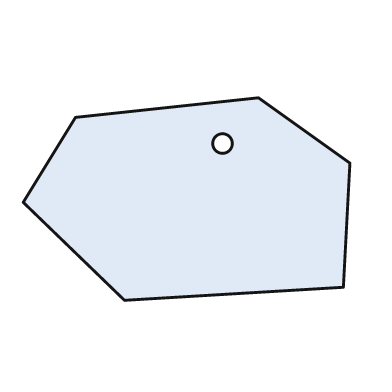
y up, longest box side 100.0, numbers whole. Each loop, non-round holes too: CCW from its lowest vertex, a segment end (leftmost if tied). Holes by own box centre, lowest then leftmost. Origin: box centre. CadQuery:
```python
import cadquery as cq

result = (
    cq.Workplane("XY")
    .moveTo(-19.0, -31.0)
    .lineTo(48.0, -27.0)
    .lineTo(50.0, 11.0)
    .lineTo(22.0, 31.0)
    .lineTo(-34.0, 25.0)
    .lineTo(-50.0, -1.0)
    .close()
    .moveTo(11.0, 17.0)
    .circle(3.0)
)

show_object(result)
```